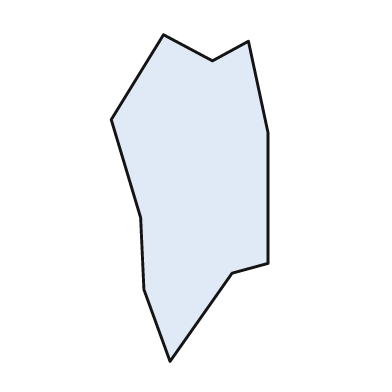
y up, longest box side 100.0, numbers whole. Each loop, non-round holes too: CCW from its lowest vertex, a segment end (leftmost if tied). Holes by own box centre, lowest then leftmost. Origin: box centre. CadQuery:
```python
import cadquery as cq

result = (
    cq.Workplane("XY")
    .moveTo(-6.0, -50.0)
    .lineTo(13.0, -23.0)
    .lineTo(24.0, -20.0)
    .lineTo(24.0, 20.0)
    .lineTo(18.0, 48.0)
    .lineTo(7.0, 42.0)
    .lineTo(-8.0, 50.0)
    .lineTo(-24.0, 24.0)
    .lineTo(-15.0, -6.0)
    .lineTo(-14.0, -28.0)
    .close()
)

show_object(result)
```